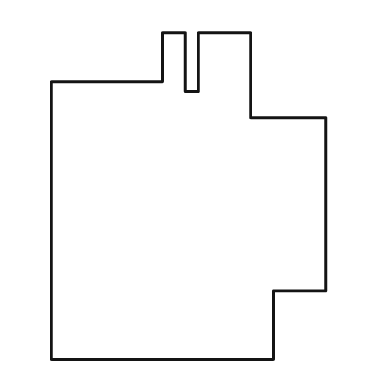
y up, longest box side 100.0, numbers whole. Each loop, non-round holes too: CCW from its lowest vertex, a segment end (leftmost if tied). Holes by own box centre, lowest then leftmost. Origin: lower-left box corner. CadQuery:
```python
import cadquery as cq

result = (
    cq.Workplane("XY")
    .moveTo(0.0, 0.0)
    .lineTo(68.0, 0.0)
    .lineTo(68.0, 21.0)
    .lineTo(84.0, 21.0)
    .lineTo(84.0, 74.0)
    .lineTo(61.0, 74.0)
    .lineTo(61.0, 100.0)
    .lineTo(45.0, 100.0)
    .lineTo(45.0, 82.0)
    .lineTo(41.0, 82.0)
    .lineTo(41.0, 100.0)
    .lineTo(34.0, 100.0)
    .lineTo(34.0, 85.0)
    .lineTo(0.0, 85.0)
    .close()
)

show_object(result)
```